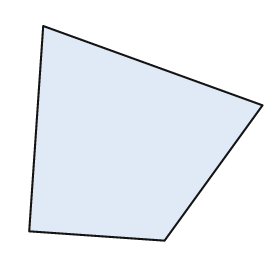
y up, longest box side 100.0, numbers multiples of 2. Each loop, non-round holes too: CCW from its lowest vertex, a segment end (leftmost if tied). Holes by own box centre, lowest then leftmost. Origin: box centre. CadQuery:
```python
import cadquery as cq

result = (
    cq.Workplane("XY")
    .moveTo(8.0, -46.0)
    .lineTo(50.0, 12.0)
    .lineTo(-44.0, 46.0)
    .lineTo(-50.0, -42.0)
    .close()
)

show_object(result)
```